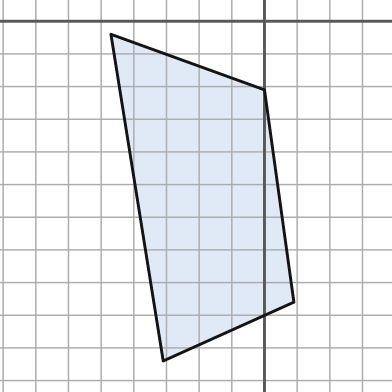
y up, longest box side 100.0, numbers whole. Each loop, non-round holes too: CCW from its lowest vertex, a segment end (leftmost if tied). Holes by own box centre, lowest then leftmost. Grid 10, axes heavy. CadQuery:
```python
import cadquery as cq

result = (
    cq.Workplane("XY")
    .moveTo(-31.0, -104.0)
    .lineTo(9.0, -86.0)
    .lineTo(0.0, -21.0)
    .lineTo(-47.0, -4.0)
    .close()
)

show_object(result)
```